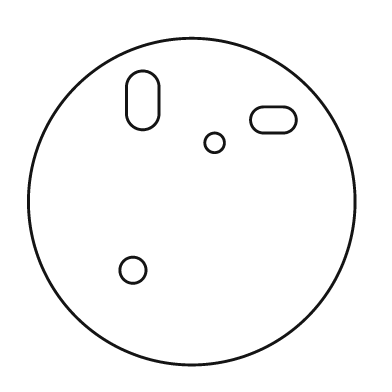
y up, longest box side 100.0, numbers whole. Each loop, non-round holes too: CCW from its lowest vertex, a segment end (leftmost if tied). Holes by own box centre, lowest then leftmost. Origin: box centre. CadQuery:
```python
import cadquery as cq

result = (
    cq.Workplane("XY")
    .moveTo(0.0, 0.0)
    .circle(50.0)
    .moveTo(-18.0, -21.0)
    .circle(4.0)
    .moveTo(7.0, 18.0)
    .circle(3.0)
    .moveTo(22.0, 21.0)
    .lineTo(28.0, 21.0)
    .threePointArc((32.0, 25.0), (28.0, 29.0))
    .lineTo(22.0, 29.0)
    .threePointArc((18.0, 25.0), (22.0, 21.0))
    .close()
    .moveTo(-20.0, 27.0)
    .threePointArc((-15.0, 22.0), (-10.0, 27.0))
    .lineTo(-10.0, 35.0)
    .threePointArc((-15.0, 40.0), (-20.0, 35.0))
    .close()
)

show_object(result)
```